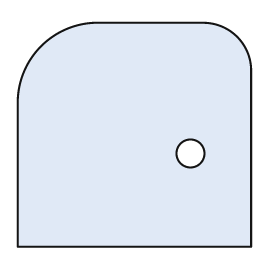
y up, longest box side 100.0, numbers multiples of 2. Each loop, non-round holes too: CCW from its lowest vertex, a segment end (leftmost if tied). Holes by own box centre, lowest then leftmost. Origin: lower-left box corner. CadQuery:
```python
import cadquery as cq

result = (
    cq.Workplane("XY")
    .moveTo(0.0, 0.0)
    .lineTo(100.0, 0.0)
    .lineTo(100.0, 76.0)
    .threePointArc((94.0, 90.0), (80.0, 96.0))
    .lineTo(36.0, 96.0)
    .threePointArc((10.0, 86.0), (0.0, 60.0))
    .close()
    .moveTo(74.0, 40.0)
    .circle(6.0)
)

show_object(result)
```